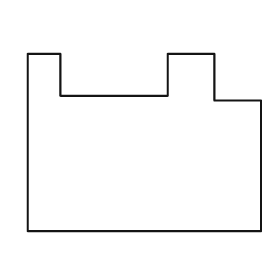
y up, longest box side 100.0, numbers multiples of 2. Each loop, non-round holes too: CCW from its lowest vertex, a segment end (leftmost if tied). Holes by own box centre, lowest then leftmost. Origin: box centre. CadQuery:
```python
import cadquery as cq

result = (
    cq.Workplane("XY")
    .moveTo(-50.0, -38.0)
    .lineTo(50.0, -38.0)
    .lineTo(50.0, 18.0)
    .lineTo(30.0, 18.0)
    .lineTo(30.0, 38.0)
    .lineTo(10.0, 38.0)
    .lineTo(10.0, 20.0)
    .lineTo(-36.0, 20.0)
    .lineTo(-36.0, 38.0)
    .lineTo(-50.0, 38.0)
    .close()
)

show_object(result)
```